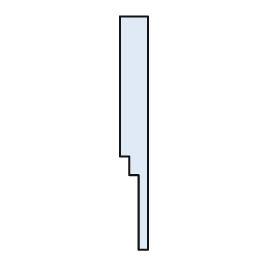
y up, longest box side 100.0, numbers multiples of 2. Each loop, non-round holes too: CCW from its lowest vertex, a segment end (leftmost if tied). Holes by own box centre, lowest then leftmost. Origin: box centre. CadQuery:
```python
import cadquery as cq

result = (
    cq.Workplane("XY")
    .moveTo(2.0, -50.0)
    .lineTo(6.0, -50.0)
    .lineTo(6.0, 50.0)
    .lineTo(-6.0, 50.0)
    .lineTo(-6.0, -10.0)
    .lineTo(-2.0, -10.0)
    .lineTo(-2.0, -18.0)
    .lineTo(2.0, -18.0)
    .close()
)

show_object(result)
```